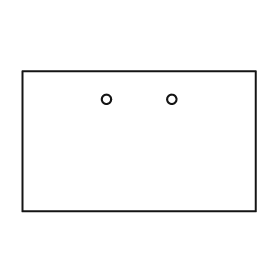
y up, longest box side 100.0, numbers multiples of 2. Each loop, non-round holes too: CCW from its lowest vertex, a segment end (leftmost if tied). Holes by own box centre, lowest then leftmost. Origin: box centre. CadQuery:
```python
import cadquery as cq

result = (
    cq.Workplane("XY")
    .moveTo(-50.0, -30.0)
    .lineTo(50.0, -30.0)
    .lineTo(50.0, 30.0)
    .lineTo(-50.0, 30.0)
    .close()
    .moveTo(-14.0, 18.0)
    .circle(2.0)
    .moveTo(14.0, 18.0)
    .circle(2.0)
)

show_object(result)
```